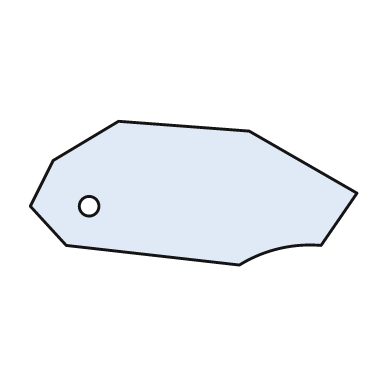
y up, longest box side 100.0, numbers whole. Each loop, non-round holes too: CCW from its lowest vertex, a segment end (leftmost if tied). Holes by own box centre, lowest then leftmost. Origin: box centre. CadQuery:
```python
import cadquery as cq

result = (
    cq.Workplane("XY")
    .moveTo(14.0, -22.0)
    .threePointArc((26.0, -17.0), (39.0, -16.0))
    .lineTo(50.0, 0.0)
    .lineTo(17.0, 19.0)
    .lineTo(-23.0, 22.0)
    .lineTo(-43.0, 10.0)
    .lineTo(-50.0, -4.0)
    .lineTo(-39.0, -16.0)
    .close()
    .moveTo(-32.0, -4.0)
    .circle(3.0)
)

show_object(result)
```